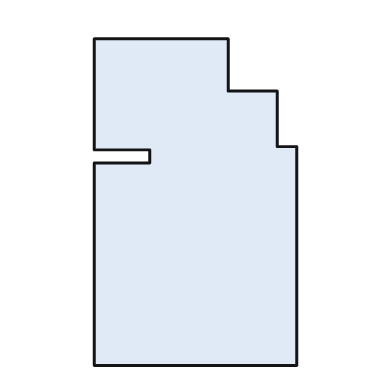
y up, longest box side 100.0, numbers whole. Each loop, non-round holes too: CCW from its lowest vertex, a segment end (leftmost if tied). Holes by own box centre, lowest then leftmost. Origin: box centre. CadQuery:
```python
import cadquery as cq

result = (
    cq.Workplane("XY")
    .moveTo(-31.0, -50.0)
    .lineTo(31.0, -50.0)
    .lineTo(31.0, 17.0)
    .lineTo(25.0, 17.0)
    .lineTo(25.0, 34.0)
    .lineTo(10.0, 34.0)
    .lineTo(10.0, 50.0)
    .lineTo(-31.0, 50.0)
    .lineTo(-31.0, 16.0)
    .lineTo(-14.0, 16.0)
    .lineTo(-14.0, 12.0)
    .lineTo(-31.0, 12.0)
    .close()
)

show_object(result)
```